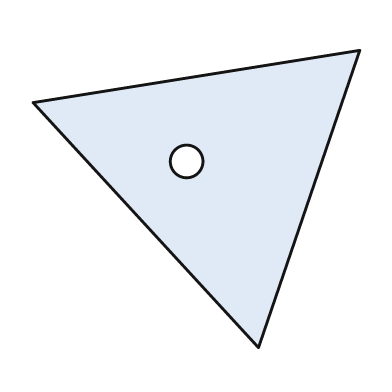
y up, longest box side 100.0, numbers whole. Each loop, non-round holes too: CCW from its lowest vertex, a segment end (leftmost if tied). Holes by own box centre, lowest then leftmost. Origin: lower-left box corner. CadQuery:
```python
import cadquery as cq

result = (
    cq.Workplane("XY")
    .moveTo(69.0, 0.0)
    .lineTo(100.0, 91.0)
    .lineTo(0.0, 75.0)
    .close()
    .moveTo(47.0, 57.0)
    .circle(5.0)
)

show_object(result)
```